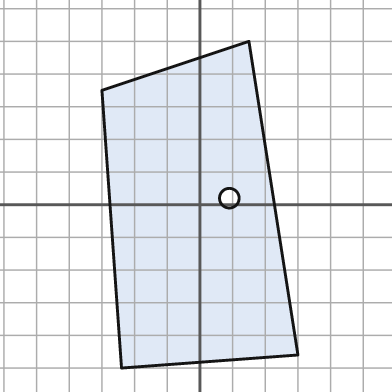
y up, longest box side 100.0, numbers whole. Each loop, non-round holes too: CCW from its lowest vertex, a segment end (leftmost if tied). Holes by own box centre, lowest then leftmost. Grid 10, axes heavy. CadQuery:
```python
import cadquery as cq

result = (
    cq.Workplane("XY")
    .moveTo(-24.0, -50.0)
    .lineTo(30.0, -46.0)
    .lineTo(15.0, 50.0)
    .lineTo(-30.0, 35.0)
    .close()
    .moveTo(9.0, 2.0)
    .circle(3.0)
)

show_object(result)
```